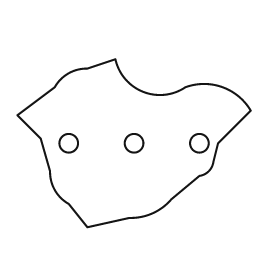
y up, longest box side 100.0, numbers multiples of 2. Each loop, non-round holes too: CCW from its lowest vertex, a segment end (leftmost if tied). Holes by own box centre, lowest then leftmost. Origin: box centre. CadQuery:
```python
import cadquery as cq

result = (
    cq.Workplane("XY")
    .moveTo(-20.0, -36.0)
    .lineTo(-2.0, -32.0)
    .threePointArc((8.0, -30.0), (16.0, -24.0))
    .lineTo(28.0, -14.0)
    .threePointArc((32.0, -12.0), (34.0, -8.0))
    .lineTo(36.0, 0.0)
    .lineTo(50.0, 14.0)
    .threePointArc((38.0, 24.0), (22.0, 24.0))
    .threePointArc((4.0, 22.0), (-8.0, 36.0))
    .lineTo(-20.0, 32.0)
    .threePointArc((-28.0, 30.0), (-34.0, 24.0))
    .lineTo(-50.0, 12.0)
    .lineTo(-40.0, 2.0)
    .lineTo(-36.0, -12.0)
    .threePointArc((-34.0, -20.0), (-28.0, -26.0))
    .close()
    .moveTo(-28.0, 0.0)
    .circle(4.0)
    .moveTo(0.0, 0.0)
    .circle(4.0)
    .moveTo(28.0, 0.0)
    .circle(4.0)
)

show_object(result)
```